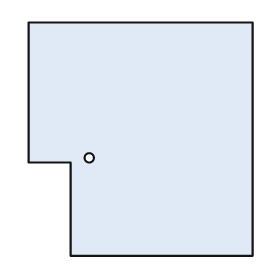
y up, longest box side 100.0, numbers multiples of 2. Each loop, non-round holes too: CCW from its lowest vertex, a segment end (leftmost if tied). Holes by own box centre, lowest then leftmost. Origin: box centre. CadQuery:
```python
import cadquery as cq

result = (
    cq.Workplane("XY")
    .moveTo(-30.0, -50.0)
    .lineTo(48.0, -50.0)
    .lineTo(48.0, 50.0)
    .lineTo(-48.0, 50.0)
    .lineTo(-48.0, -10.0)
    .lineTo(-30.0, -10.0)
    .close()
    .moveTo(-22.0, -8.0)
    .circle(2.0)
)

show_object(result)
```